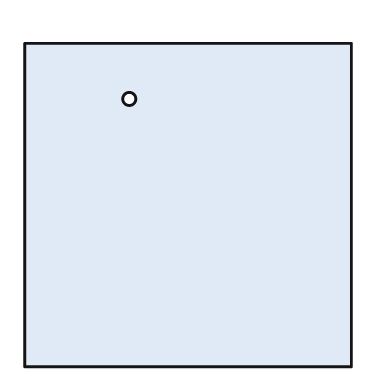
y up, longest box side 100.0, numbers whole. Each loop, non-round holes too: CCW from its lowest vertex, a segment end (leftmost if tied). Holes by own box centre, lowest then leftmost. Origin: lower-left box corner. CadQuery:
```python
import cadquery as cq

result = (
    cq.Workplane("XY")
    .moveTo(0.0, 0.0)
    .lineTo(100.0, 0.0)
    .lineTo(100.0, 99.0)
    .lineTo(0.0, 99.0)
    .close()
    .moveTo(32.0, 82.0)
    .circle(2.0)
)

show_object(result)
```